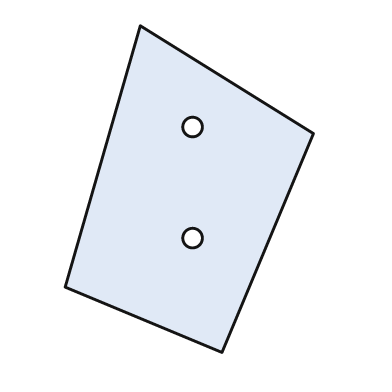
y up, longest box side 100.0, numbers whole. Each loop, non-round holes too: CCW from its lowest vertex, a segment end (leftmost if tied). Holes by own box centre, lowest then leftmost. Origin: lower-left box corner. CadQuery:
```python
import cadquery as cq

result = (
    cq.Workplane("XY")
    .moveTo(48.0, 0.0)
    .lineTo(76.0, 67.0)
    .lineTo(23.0, 100.0)
    .lineTo(0.0, 20.0)
    .close()
    .moveTo(39.0, 35.0)
    .circle(3.0)
    .moveTo(39.0, 69.0)
    .circle(3.0)
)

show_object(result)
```